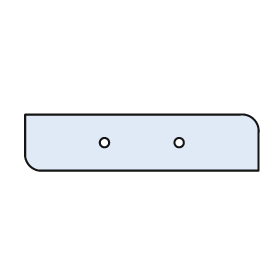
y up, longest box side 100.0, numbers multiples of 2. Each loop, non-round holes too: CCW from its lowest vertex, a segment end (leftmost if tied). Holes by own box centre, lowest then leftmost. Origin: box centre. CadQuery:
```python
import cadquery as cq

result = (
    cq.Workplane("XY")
    .moveTo(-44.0, -12.0)
    .lineTo(50.0, -12.0)
    .lineTo(50.0, 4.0)
    .threePointArc((48.0, 10.0), (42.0, 12.0))
    .lineTo(-50.0, 12.0)
    .lineTo(-50.0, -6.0)
    .threePointArc((-48.0, -10.0), (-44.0, -12.0))
    .close()
    .moveTo(-16.0, 0.0)
    .circle(2.0)
    .moveTo(16.0, 0.0)
    .circle(2.0)
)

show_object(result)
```